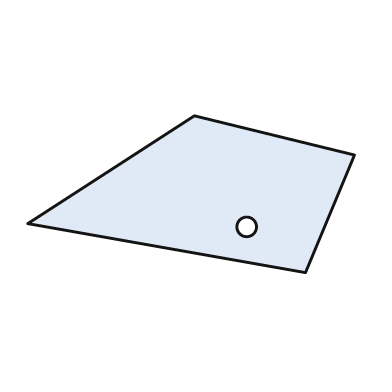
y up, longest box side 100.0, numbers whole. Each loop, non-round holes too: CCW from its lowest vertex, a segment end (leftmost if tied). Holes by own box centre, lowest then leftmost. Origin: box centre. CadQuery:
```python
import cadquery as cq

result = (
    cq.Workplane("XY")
    .moveTo(35.0, -24.0)
    .lineTo(50.0, 12.0)
    .lineTo(1.0, 24.0)
    .lineTo(-50.0, -9.0)
    .close()
    .moveTo(17.0, -10.0)
    .circle(3.0)
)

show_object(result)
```